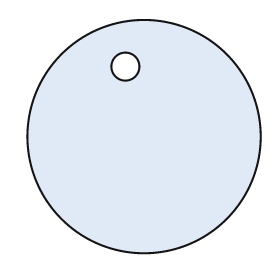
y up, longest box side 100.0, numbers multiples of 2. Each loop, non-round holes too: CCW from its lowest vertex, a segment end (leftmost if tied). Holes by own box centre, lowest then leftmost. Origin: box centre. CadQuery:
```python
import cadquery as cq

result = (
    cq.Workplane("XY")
    .moveTo(0.0, 0.0)
    .circle(50.0)
    .moveTo(-8.0, 30.0)
    .circle(6.0)
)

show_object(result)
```